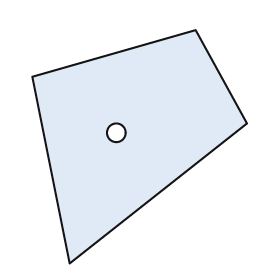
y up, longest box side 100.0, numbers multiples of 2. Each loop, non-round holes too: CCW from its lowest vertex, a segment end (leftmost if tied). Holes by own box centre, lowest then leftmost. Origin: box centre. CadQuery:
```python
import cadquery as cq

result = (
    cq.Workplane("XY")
    .moveTo(-30.0, -50.0)
    .lineTo(46.0, 10.0)
    .lineTo(24.0, 50.0)
    .lineTo(-46.0, 30.0)
    .close()
    .moveTo(-10.0, 6.0)
    .circle(4.0)
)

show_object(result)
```